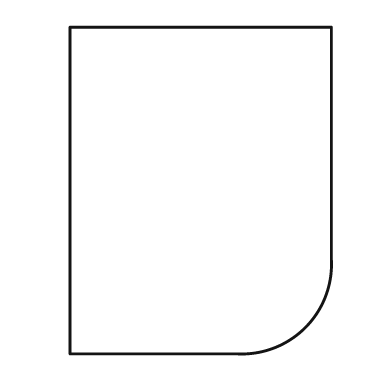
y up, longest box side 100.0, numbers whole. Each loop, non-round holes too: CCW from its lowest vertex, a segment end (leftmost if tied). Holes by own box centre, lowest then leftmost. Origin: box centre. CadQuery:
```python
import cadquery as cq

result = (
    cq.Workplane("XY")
    .moveTo(-40.0, -50.0)
    .lineTo(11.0, -50.0)
    .threePointArc((32.0, -42.0), (40.0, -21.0))
    .lineTo(40.0, 50.0)
    .lineTo(-40.0, 50.0)
    .close()
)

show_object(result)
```